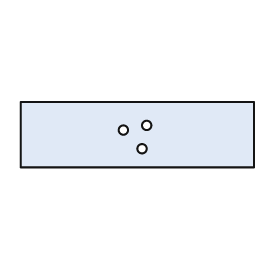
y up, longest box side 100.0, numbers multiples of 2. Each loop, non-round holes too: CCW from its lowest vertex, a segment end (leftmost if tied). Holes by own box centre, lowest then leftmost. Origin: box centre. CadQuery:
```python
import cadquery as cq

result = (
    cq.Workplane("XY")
    .moveTo(-50.0, -14.0)
    .lineTo(50.0, -14.0)
    .lineTo(50.0, 14.0)
    .lineTo(-50.0, 14.0)
    .close()
    .moveTo(2.0, -6.0)
    .circle(2.0)
    .moveTo(-6.0, 2.0)
    .circle(2.0)
    .moveTo(4.0, 4.0)
    .circle(2.0)
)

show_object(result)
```